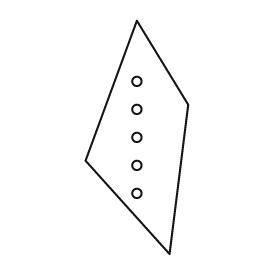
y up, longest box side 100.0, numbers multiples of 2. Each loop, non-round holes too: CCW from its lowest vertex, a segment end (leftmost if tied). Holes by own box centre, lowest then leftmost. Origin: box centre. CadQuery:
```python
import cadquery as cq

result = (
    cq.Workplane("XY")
    .moveTo(14.0, -50.0)
    .lineTo(22.0, 14.0)
    .lineTo(0.0, 50.0)
    .lineTo(-22.0, -10.0)
    .close()
    .moveTo(0.0, -24.0)
    .circle(2.0)
    .moveTo(0.0, -12.0)
    .circle(2.0)
    .moveTo(0.0, 0.0)
    .circle(2.0)
    .moveTo(0.0, 12.0)
    .circle(2.0)
    .moveTo(0.0, 24.0)
    .circle(2.0)
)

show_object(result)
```